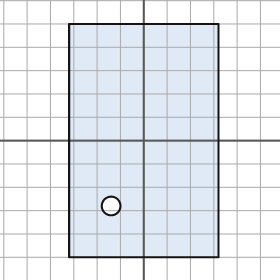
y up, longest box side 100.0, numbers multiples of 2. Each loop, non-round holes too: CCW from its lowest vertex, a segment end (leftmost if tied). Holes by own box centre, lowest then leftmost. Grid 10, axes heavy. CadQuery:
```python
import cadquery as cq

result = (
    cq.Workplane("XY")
    .moveTo(-32.0, -50.0)
    .lineTo(32.0, -50.0)
    .lineTo(32.0, 50.0)
    .lineTo(-32.0, 50.0)
    .close()
    .moveTo(-14.0, -28.0)
    .circle(4.0)
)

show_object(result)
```